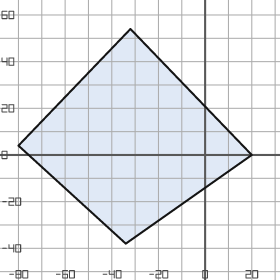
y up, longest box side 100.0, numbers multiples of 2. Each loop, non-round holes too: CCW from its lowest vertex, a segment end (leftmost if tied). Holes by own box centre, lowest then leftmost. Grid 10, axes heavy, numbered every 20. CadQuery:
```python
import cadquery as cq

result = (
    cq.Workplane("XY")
    .moveTo(-34.0, -38.0)
    .lineTo(20.0, 0.0)
    .lineTo(-32.0, 54.0)
    .lineTo(-80.0, 4.0)
    .close()
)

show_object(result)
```